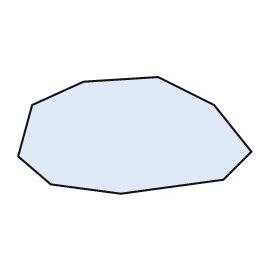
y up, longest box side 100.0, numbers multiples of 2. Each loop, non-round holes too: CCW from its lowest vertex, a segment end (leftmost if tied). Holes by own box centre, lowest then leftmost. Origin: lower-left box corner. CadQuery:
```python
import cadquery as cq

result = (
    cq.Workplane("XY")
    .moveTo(44.0, 0.0)
    .lineTo(88.0, 6.0)
    .lineTo(100.0, 18.0)
    .lineTo(84.0, 38.0)
    .lineTo(60.0, 50.0)
    .lineTo(28.0, 48.0)
    .lineTo(6.0, 38.0)
    .lineTo(0.0, 16.0)
    .lineTo(14.0, 4.0)
    .close()
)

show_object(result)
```